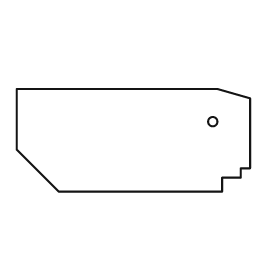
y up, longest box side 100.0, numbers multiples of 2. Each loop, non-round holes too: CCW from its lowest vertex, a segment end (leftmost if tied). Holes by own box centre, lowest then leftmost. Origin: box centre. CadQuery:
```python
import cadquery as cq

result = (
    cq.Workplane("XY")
    .moveTo(-32.0, -22.0)
    .lineTo(38.0, -22.0)
    .lineTo(38.0, -16.0)
    .lineTo(46.0, -16.0)
    .lineTo(46.0, -12.0)
    .lineTo(50.0, -12.0)
    .lineTo(50.0, 18.0)
    .lineTo(36.0, 22.0)
    .lineTo(-50.0, 22.0)
    .lineTo(-50.0, -4.0)
    .close()
    .moveTo(34.0, 8.0)
    .circle(2.0)
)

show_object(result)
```